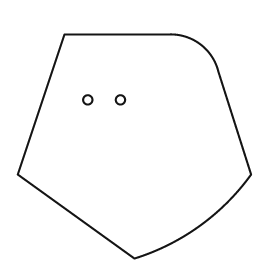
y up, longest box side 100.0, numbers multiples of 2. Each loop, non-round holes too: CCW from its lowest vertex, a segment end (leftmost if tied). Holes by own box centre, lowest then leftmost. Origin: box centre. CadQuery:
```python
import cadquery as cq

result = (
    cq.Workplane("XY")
    .moveTo(0.0, -48.0)
    .threePointArc((28.0, -34.0), (50.0, -12.0))
    .lineTo(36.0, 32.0)
    .threePointArc((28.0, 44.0), (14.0, 48.0))
    .lineTo(-30.0, 48.0)
    .lineTo(-50.0, -12.0)
    .close()
    .moveTo(-20.0, 20.0)
    .circle(2.0)
    .moveTo(-6.0, 20.0)
    .circle(2.0)
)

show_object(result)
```